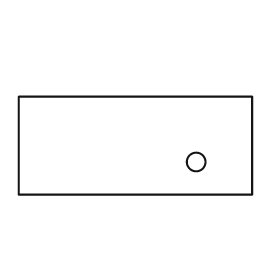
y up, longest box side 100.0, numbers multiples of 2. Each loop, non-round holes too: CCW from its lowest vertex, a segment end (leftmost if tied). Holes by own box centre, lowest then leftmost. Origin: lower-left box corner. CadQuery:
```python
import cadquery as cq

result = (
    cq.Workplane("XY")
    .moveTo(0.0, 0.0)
    .lineTo(100.0, 0.0)
    .lineTo(100.0, 42.0)
    .lineTo(0.0, 42.0)
    .close()
    .moveTo(76.0, 14.0)
    .circle(4.0)
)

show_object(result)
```